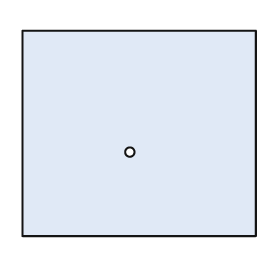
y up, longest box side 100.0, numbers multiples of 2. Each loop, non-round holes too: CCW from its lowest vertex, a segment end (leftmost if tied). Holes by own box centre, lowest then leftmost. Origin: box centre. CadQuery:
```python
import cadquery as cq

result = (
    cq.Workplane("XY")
    .moveTo(-50.0, -44.0)
    .lineTo(50.0, -44.0)
    .lineTo(50.0, 44.0)
    .lineTo(-50.0, 44.0)
    .close()
    .moveTo(-4.0, -8.0)
    .circle(2.0)
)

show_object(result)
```